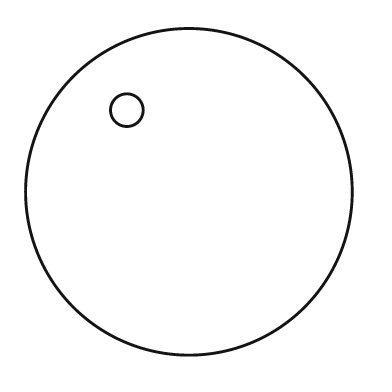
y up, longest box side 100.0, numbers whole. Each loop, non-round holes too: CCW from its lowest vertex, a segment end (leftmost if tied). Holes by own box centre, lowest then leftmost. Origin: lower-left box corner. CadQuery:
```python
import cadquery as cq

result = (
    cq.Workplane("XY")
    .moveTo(50.0, 50.0)
    .circle(50.0)
    .moveTo(31.0, 75.0)
    .circle(5.0)
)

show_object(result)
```